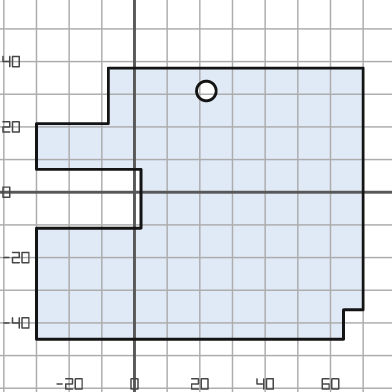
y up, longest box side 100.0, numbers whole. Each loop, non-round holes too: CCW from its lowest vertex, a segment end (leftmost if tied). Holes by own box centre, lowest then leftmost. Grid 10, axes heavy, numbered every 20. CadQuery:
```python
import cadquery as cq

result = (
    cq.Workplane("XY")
    .moveTo(-30.0, -45.0)
    .lineTo(64.0, -45.0)
    .lineTo(64.0, -36.0)
    .lineTo(70.0, -36.0)
    .lineTo(70.0, 38.0)
    .lineTo(-8.0, 38.0)
    .lineTo(-8.0, 21.0)
    .lineTo(-30.0, 21.0)
    .lineTo(-30.0, 7.0)
    .lineTo(2.0, 7.0)
    .lineTo(2.0, -11.0)
    .lineTo(-30.0, -11.0)
    .close()
    .moveTo(22.0, 31.0)
    .circle(3.0)
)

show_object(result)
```